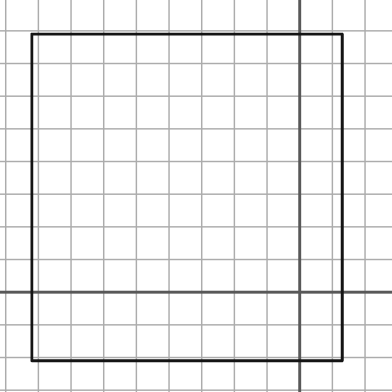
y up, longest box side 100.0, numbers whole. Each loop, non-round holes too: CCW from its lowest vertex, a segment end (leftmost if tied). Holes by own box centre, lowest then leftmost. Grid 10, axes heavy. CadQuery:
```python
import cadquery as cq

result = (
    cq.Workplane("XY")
    .moveTo(-82.0, -21.0)
    .lineTo(13.0, -21.0)
    .lineTo(13.0, 79.0)
    .lineTo(-82.0, 79.0)
    .close()
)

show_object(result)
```